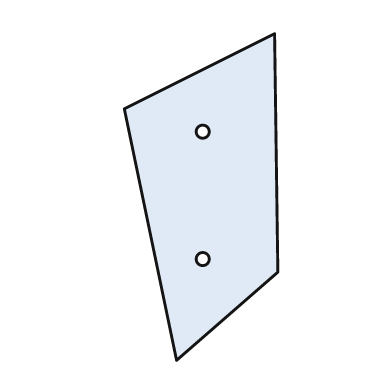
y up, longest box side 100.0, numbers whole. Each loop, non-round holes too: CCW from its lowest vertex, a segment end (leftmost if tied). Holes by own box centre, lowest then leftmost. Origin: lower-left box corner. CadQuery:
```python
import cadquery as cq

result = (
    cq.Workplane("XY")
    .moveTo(16.0, 0.0)
    .lineTo(47.0, 27.0)
    .lineTo(46.0, 100.0)
    .lineTo(0.0, 77.0)
    .close()
    .moveTo(24.0, 31.0)
    .circle(2.0)
    .moveTo(24.0, 70.0)
    .circle(2.0)
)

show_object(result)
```